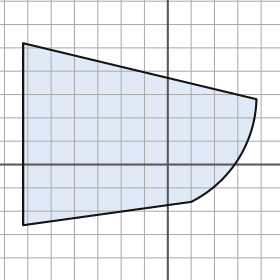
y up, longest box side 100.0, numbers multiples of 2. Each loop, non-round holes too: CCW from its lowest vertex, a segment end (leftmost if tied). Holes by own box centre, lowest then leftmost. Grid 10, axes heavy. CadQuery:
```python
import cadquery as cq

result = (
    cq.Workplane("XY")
    .moveTo(-62.0, -26.0)
    .lineTo(10.0, -16.0)
    .threePointArc((30.0, 2.0), (38.0, 28.0))
    .lineTo(-62.0, 52.0)
    .close()
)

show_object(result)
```